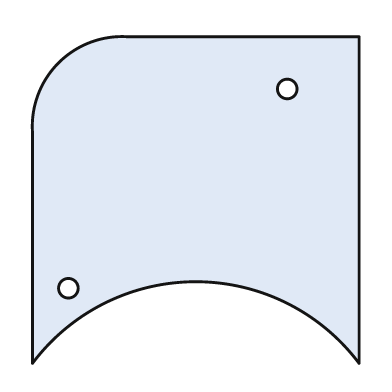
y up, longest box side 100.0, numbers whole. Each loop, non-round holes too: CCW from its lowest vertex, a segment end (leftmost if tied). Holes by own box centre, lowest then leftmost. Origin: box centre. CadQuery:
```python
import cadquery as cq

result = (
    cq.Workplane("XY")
    .moveTo(-50.0, -50.0)
    .threePointArc((0.0, -25.0), (50.0, -50.0))
    .lineTo(50.0, 50.0)
    .lineTo(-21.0, 50.0)
    .threePointArc((-42.0, 42.0), (-50.0, 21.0))
    .close()
    .moveTo(-39.0, -27.0)
    .circle(3.0)
    .moveTo(28.0, 34.0)
    .circle(3.0)
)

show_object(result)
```